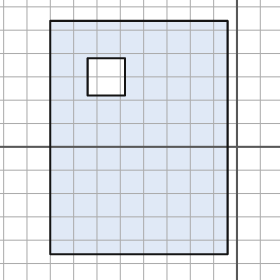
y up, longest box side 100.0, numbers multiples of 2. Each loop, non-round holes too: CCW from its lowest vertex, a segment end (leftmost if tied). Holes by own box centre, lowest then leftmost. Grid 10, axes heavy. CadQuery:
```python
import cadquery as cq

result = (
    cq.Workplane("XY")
    .moveTo(-80.0, -46.0)
    .lineTo(-4.0, -46.0)
    .lineTo(-4.0, 54.0)
    .lineTo(-80.0, 54.0)
    .close()
    .moveTo(-64.0, 22.0)
    .lineTo(-48.0, 22.0)
    .lineTo(-48.0, 38.0)
    .lineTo(-64.0, 38.0)
    .close()
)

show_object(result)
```